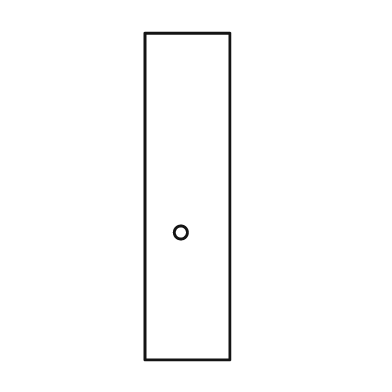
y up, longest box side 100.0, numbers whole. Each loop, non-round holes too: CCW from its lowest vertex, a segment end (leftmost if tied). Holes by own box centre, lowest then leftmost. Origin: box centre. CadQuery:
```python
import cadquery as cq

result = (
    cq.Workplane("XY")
    .moveTo(-13.0, -50.0)
    .lineTo(13.0, -50.0)
    .lineTo(13.0, 50.0)
    .lineTo(-13.0, 50.0)
    .close()
    .moveTo(-2.0, -11.0)
    .circle(2.0)
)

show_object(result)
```